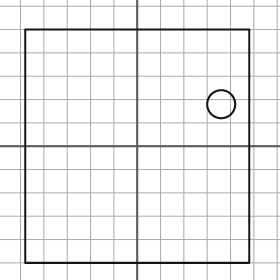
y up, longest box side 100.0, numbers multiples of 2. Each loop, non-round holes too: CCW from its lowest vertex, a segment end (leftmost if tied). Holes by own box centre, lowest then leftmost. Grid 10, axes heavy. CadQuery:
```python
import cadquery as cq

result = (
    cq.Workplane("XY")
    .moveTo(-48.0, -50.0)
    .lineTo(48.0, -50.0)
    .lineTo(48.0, 50.0)
    .lineTo(-48.0, 50.0)
    .close()
    .moveTo(36.0, 18.0)
    .circle(6.0)
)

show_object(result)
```